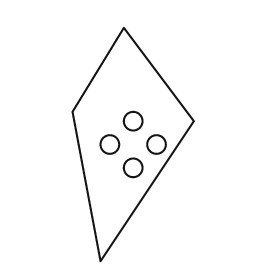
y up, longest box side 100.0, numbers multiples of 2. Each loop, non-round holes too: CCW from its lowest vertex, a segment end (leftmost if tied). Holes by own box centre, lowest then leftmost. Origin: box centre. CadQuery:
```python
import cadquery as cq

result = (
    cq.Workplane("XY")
    .moveTo(-14.0, -50.0)
    .lineTo(26.0, 10.0)
    .lineTo(-4.0, 50.0)
    .lineTo(-26.0, 14.0)
    .close()
    .moveTo(0.0, -10.0)
    .circle(4.0)
    .moveTo(-10.0, 0.0)
    .circle(4.0)
    .moveTo(10.0, 0.0)
    .circle(4.0)
    .moveTo(0.0, 10.0)
    .circle(4.0)
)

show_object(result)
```